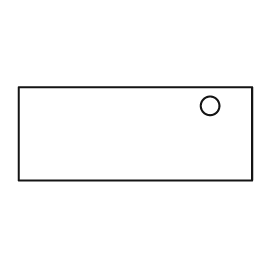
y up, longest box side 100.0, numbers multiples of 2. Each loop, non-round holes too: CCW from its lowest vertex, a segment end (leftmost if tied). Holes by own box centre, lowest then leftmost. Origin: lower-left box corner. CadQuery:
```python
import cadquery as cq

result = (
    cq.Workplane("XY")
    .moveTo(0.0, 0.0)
    .lineTo(100.0, 0.0)
    .lineTo(100.0, 40.0)
    .lineTo(0.0, 40.0)
    .close()
    .moveTo(82.0, 32.0)
    .circle(4.0)
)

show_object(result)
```